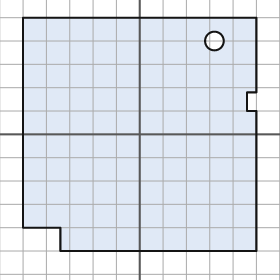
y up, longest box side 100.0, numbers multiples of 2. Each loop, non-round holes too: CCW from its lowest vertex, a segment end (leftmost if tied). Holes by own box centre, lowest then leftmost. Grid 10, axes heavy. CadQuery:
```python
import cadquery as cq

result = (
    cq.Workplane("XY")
    .moveTo(-34.0, -50.0)
    .lineTo(50.0, -50.0)
    .lineTo(50.0, 10.0)
    .lineTo(46.0, 10.0)
    .lineTo(46.0, 18.0)
    .lineTo(50.0, 18.0)
    .lineTo(50.0, 50.0)
    .lineTo(-50.0, 50.0)
    .lineTo(-50.0, -40.0)
    .lineTo(-34.0, -40.0)
    .close()
    .moveTo(32.0, 40.0)
    .circle(4.0)
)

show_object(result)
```